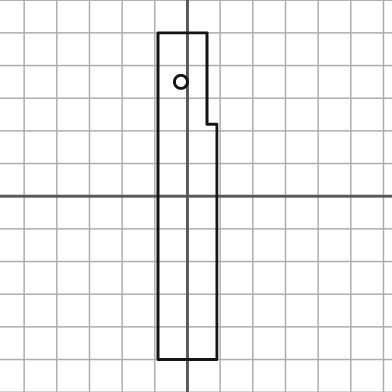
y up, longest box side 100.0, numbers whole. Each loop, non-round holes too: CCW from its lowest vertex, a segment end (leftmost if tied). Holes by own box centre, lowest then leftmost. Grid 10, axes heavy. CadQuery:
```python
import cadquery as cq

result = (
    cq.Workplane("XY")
    .moveTo(-9.0, -50.0)
    .lineTo(9.0, -50.0)
    .lineTo(9.0, 22.0)
    .lineTo(6.0, 22.0)
    .lineTo(6.0, 50.0)
    .lineTo(-9.0, 50.0)
    .close()
    .moveTo(-2.0, 35.0)
    .circle(2.0)
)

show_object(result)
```